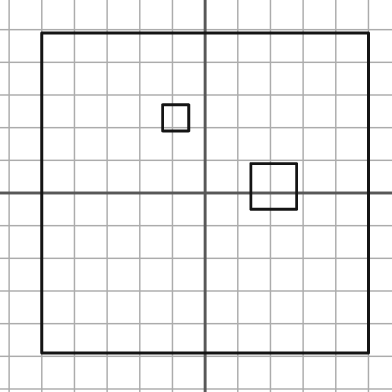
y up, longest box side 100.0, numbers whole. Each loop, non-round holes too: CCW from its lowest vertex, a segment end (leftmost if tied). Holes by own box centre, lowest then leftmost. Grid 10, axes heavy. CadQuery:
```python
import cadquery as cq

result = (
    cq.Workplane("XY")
    .moveTo(-50.0, -49.0)
    .lineTo(50.0, -49.0)
    .lineTo(50.0, 49.0)
    .lineTo(-50.0, 49.0)
    .close()
    .moveTo(14.0, -5.0)
    .lineTo(28.0, -5.0)
    .lineTo(28.0, 9.0)
    .lineTo(14.0, 9.0)
    .close()
    .moveTo(-13.0, 19.0)
    .lineTo(-5.0, 19.0)
    .lineTo(-5.0, 27.0)
    .lineTo(-13.0, 27.0)
    .close()
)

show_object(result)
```